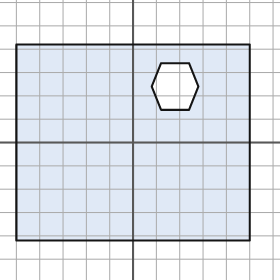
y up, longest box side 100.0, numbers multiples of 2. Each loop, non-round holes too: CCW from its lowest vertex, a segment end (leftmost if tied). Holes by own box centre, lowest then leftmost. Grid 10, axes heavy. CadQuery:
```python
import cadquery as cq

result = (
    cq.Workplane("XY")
    .moveTo(-50.0, -42.0)
    .lineTo(50.0, -42.0)
    .lineTo(50.0, 42.0)
    .lineTo(-50.0, 42.0)
    .close()
    .moveTo(12.0, 14.0)
    .lineTo(24.0, 14.0)
    .lineTo(28.0, 24.0)
    .lineTo(24.0, 34.0)
    .lineTo(12.0, 34.0)
    .lineTo(8.0, 24.0)
    .close()
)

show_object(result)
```